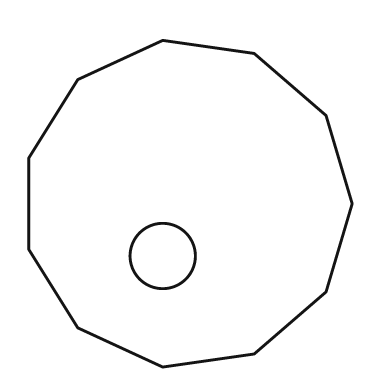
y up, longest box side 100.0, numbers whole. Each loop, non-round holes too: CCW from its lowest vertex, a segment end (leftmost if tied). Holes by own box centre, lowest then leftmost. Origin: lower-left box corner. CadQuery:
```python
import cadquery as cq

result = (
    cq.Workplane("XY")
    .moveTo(41.0, 0.0)
    .lineTo(69.0, 4.0)
    .lineTo(91.0, 23.0)
    .lineTo(99.0, 50.0)
    .lineTo(91.0, 77.0)
    .lineTo(69.0, 96.0)
    .lineTo(41.0, 100.0)
    .lineTo(15.0, 88.0)
    .lineTo(0.0, 64.0)
    .lineTo(0.0, 36.0)
    .lineTo(15.0, 12.0)
    .close()
    .moveTo(41.0, 34.0)
    .circle(10.0)
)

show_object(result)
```